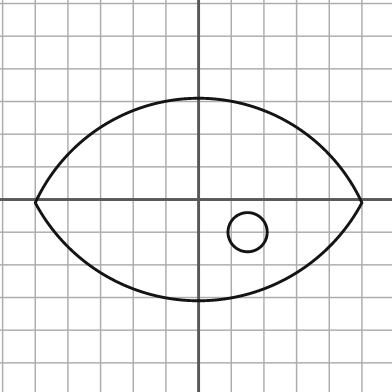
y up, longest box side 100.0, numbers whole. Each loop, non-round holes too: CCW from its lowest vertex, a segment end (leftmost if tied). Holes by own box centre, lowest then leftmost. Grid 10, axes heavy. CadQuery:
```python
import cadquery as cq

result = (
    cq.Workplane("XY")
    .moveTo(-50.0, -1.0)
    .threePointArc((0.0, -31.0), (50.0, -1.0))
    .threePointArc((0.0, 31.0), (-50.0, -1.0))
    .close()
    .moveTo(15.0, -10.0)
    .circle(6.0)
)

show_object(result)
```